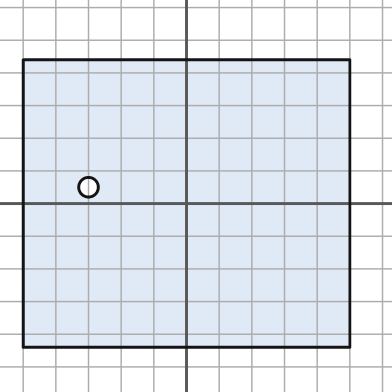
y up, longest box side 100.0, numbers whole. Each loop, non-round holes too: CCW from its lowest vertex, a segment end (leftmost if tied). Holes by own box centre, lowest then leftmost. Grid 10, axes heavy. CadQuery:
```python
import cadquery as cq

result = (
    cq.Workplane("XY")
    .moveTo(-50.0, -44.0)
    .lineTo(50.0, -44.0)
    .lineTo(50.0, 44.0)
    .lineTo(-50.0, 44.0)
    .close()
    .moveTo(-30.0, 5.0)
    .circle(3.0)
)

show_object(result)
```